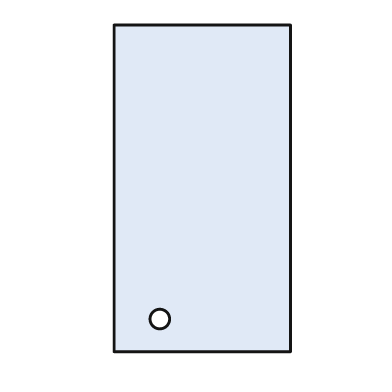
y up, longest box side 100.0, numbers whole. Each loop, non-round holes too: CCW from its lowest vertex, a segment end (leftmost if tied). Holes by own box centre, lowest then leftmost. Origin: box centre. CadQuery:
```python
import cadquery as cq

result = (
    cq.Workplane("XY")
    .moveTo(-27.0, -50.0)
    .lineTo(27.0, -50.0)
    .lineTo(27.0, 50.0)
    .lineTo(-27.0, 50.0)
    .close()
    .moveTo(-13.0, -40.0)
    .circle(3.0)
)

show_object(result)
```